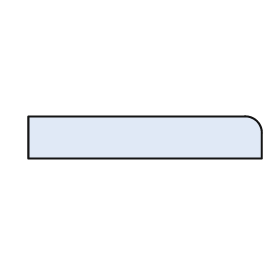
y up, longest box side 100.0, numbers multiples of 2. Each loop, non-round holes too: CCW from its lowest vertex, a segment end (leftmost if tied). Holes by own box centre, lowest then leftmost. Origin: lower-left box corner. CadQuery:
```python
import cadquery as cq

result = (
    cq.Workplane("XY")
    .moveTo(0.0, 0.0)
    .lineTo(100.0, 0.0)
    .lineTo(100.0, 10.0)
    .threePointArc((98.0, 16.0), (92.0, 18.0))
    .lineTo(0.0, 18.0)
    .close()
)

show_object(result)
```